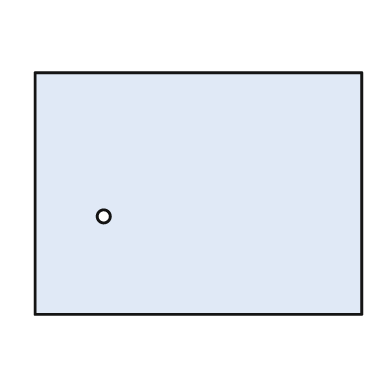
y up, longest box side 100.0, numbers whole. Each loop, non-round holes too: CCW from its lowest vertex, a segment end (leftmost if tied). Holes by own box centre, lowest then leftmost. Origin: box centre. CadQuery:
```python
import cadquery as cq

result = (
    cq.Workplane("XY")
    .moveTo(-50.0, -37.0)
    .lineTo(50.0, -37.0)
    .lineTo(50.0, 37.0)
    .lineTo(-50.0, 37.0)
    .close()
    .moveTo(-29.0, -7.0)
    .circle(2.0)
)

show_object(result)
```